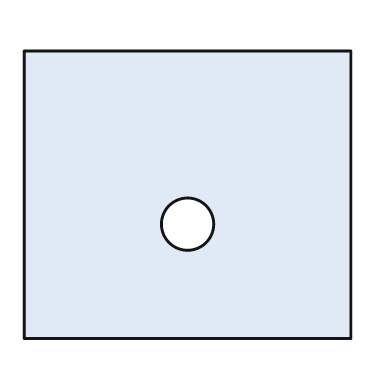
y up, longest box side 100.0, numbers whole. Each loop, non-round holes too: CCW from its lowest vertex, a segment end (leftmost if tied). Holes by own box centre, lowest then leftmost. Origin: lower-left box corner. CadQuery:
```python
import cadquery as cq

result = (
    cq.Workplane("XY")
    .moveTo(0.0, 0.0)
    .lineTo(100.0, 0.0)
    .lineTo(100.0, 88.0)
    .lineTo(0.0, 88.0)
    .close()
    .moveTo(50.0, 35.0)
    .circle(8.0)
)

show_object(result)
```